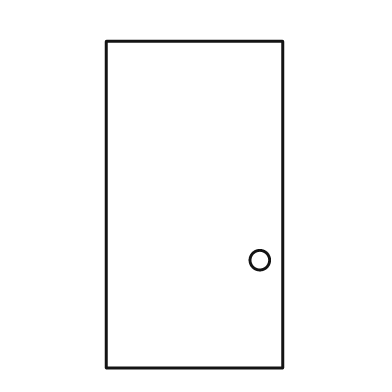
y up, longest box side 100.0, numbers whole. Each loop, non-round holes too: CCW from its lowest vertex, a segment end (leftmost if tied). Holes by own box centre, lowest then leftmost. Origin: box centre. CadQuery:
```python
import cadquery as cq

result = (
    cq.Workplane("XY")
    .moveTo(-27.0, -50.0)
    .lineTo(27.0, -50.0)
    .lineTo(27.0, 50.0)
    .lineTo(-27.0, 50.0)
    .close()
    .moveTo(20.0, -17.0)
    .circle(3.0)
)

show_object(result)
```